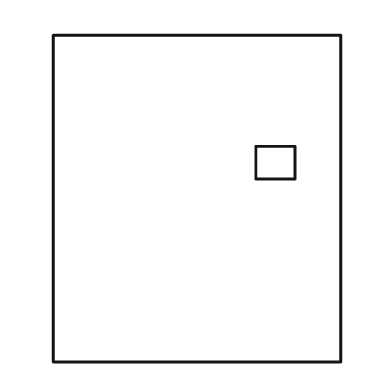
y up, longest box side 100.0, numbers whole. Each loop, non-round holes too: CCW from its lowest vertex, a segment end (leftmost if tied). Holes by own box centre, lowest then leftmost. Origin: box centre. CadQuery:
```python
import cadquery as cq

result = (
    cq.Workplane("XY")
    .moveTo(-44.0, -50.0)
    .lineTo(44.0, -50.0)
    .lineTo(44.0, 50.0)
    .lineTo(-44.0, 50.0)
    .close()
    .moveTo(18.0, 6.0)
    .lineTo(30.0, 6.0)
    .lineTo(30.0, 16.0)
    .lineTo(18.0, 16.0)
    .close()
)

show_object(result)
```